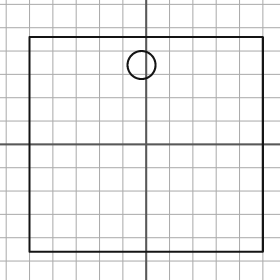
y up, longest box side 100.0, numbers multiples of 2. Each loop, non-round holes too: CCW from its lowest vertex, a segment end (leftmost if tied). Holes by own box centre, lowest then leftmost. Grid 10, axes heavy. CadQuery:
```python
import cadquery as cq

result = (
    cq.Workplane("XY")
    .moveTo(-50.0, -46.0)
    .lineTo(50.0, -46.0)
    .lineTo(50.0, 46.0)
    .lineTo(-50.0, 46.0)
    .close()
    .moveTo(-2.0, 34.0)
    .circle(6.0)
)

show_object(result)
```